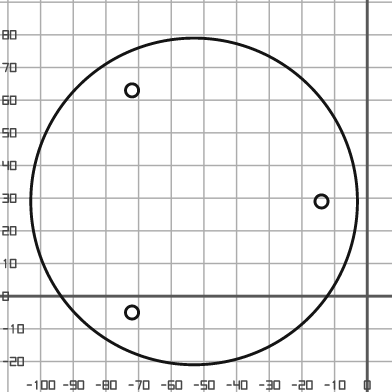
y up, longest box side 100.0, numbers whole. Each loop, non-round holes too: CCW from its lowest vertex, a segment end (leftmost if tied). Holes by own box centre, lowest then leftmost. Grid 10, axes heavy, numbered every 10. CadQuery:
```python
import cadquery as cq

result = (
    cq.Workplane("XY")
    .moveTo(-53.0, 29.0)
    .circle(50.0)
    .moveTo(-72.0, -5.0)
    .circle(2.0)
    .moveTo(-14.0, 29.0)
    .circle(2.0)
    .moveTo(-72.0, 63.0)
    .circle(2.0)
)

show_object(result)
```